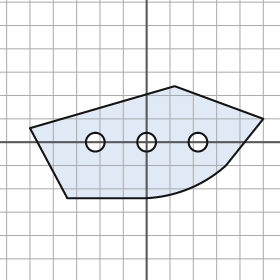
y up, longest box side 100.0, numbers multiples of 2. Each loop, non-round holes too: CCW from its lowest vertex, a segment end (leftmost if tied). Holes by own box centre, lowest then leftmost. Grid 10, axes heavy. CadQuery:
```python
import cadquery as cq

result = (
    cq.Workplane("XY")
    .moveTo(-34.0, -24.0)
    .lineTo(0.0, -24.0)
    .threePointArc((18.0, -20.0), (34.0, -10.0))
    .lineTo(50.0, 10.0)
    .lineTo(12.0, 24.0)
    .lineTo(-50.0, 6.0)
    .close()
    .moveTo(-22.0, 0.0)
    .circle(4.0)
    .moveTo(0.0, 0.0)
    .circle(4.0)
    .moveTo(22.0, 0.0)
    .circle(4.0)
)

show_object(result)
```